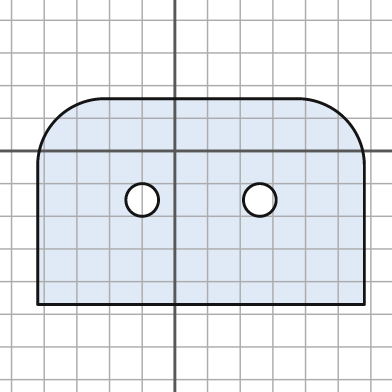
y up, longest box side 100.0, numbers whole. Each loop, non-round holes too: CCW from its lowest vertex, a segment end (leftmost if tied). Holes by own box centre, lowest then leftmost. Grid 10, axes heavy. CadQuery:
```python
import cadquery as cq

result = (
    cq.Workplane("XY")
    .moveTo(-42.0, -47.0)
    .lineTo(58.0, -47.0)
    .lineTo(58.0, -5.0)
    .threePointArc((52.0, 10.0), (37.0, 16.0))
    .lineTo(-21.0, 16.0)
    .threePointArc((-36.0, 10.0), (-42.0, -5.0))
    .close()
    .moveTo(-10.0, -15.0)
    .circle(5.0)
    .moveTo(26.0, -15.0)
    .circle(5.0)
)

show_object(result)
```